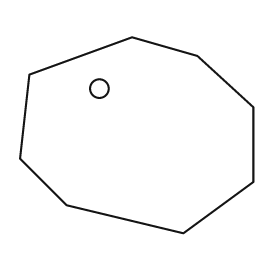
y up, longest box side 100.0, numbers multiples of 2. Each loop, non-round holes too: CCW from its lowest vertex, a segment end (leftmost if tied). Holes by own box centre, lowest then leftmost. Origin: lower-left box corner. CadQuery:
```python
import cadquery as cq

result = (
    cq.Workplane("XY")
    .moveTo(70.0, 0.0)
    .lineTo(100.0, 22.0)
    .lineTo(100.0, 54.0)
    .lineTo(76.0, 76.0)
    .lineTo(48.0, 84.0)
    .lineTo(4.0, 68.0)
    .lineTo(0.0, 32.0)
    .lineTo(20.0, 12.0)
    .close()
    .moveTo(34.0, 62.0)
    .circle(4.0)
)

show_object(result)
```